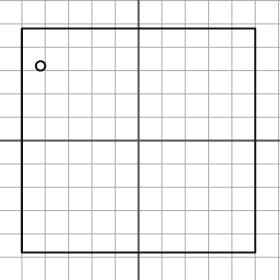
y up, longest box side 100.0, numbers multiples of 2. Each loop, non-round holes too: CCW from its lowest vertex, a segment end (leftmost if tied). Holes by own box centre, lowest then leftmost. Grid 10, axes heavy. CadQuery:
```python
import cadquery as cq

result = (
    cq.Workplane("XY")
    .moveTo(-50.0, -48.0)
    .lineTo(50.0, -48.0)
    .lineTo(50.0, 48.0)
    .lineTo(-50.0, 48.0)
    .close()
    .moveTo(-42.0, 32.0)
    .circle(2.0)
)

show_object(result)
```